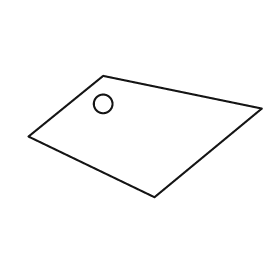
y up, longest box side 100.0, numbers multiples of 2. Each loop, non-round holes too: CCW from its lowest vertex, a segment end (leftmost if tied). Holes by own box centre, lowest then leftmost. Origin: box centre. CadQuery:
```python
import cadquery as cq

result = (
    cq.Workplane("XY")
    .moveTo(4.0, -26.0)
    .lineTo(50.0, 12.0)
    .lineTo(-18.0, 26.0)
    .lineTo(-50.0, 0.0)
    .close()
    .moveTo(-18.0, 14.0)
    .circle(4.0)
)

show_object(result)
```